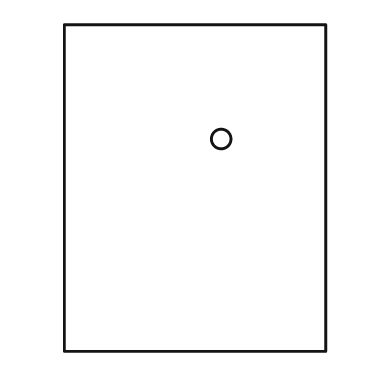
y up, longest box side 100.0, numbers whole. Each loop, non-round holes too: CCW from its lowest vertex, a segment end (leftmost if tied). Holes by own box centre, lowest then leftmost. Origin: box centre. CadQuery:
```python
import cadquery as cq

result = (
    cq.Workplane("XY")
    .moveTo(-40.0, -50.0)
    .lineTo(40.0, -50.0)
    .lineTo(40.0, 50.0)
    .lineTo(-40.0, 50.0)
    .close()
    .moveTo(8.0, 15.0)
    .circle(3.0)
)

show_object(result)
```